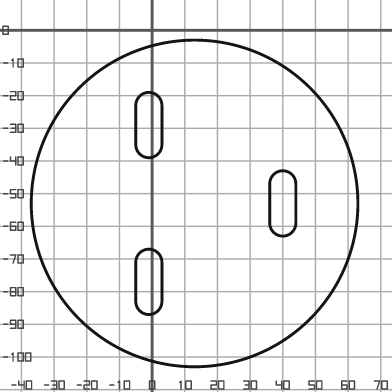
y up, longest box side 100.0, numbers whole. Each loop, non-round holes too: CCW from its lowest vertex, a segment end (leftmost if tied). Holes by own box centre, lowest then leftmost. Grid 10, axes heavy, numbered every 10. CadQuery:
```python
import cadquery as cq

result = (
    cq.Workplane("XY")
    .moveTo(13.0, -53.0)
    .circle(50.0)
    .moveTo(-5.0, -83.0)
    .threePointArc((-1.0, -87.0), (3.0, -83.0))
    .lineTo(3.0, -71.0)
    .threePointArc((-1.0, -67.0), (-5.0, -71.0))
    .close()
    .moveTo(36.0, -59.0)
    .threePointArc((40.0, -63.0), (44.0, -59.0))
    .lineTo(44.0, -47.0)
    .threePointArc((40.0, -43.0), (36.0, -47.0))
    .close()
    .moveTo(-5.0, -35.0)
    .threePointArc((-1.0, -39.0), (3.0, -35.0))
    .lineTo(3.0, -23.0)
    .threePointArc((-1.0, -19.0), (-5.0, -23.0))
    .close()
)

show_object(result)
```